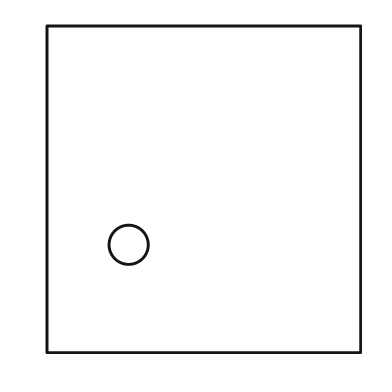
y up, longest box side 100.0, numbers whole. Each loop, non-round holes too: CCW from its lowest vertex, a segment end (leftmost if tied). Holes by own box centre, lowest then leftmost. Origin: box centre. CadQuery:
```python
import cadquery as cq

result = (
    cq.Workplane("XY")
    .moveTo(-48.0, -50.0)
    .lineTo(48.0, -50.0)
    .lineTo(48.0, 50.0)
    .lineTo(-48.0, 50.0)
    .close()
    .moveTo(-23.0, -17.0)
    .circle(6.0)
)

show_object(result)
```